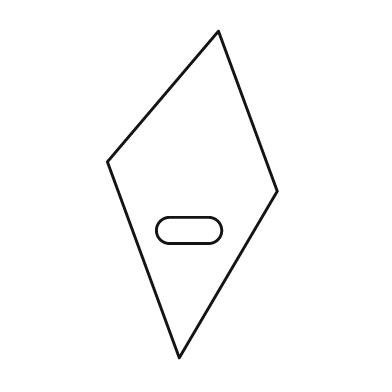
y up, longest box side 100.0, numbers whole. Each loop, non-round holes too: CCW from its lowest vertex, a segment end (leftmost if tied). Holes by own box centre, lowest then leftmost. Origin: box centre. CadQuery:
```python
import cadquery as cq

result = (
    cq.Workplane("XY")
    .moveTo(-4.0, -50.0)
    .lineTo(26.0, 1.0)
    .lineTo(8.0, 50.0)
    .lineTo(-26.0, 10.0)
    .close()
    .moveTo(-7.0, -15.0)
    .lineTo(5.0, -15.0)
    .threePointArc((9.0, -11.0), (5.0, -7.0))
    .lineTo(-7.0, -7.0)
    .threePointArc((-11.0, -11.0), (-7.0, -15.0))
    .close()
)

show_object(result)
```